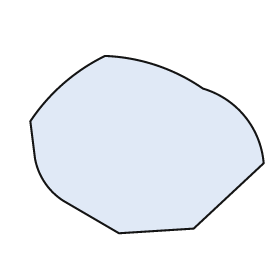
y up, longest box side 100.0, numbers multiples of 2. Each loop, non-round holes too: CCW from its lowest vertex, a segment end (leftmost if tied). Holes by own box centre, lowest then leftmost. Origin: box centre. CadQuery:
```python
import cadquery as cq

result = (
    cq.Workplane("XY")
    .moveTo(-12.0, -38.0)
    .lineTo(20.0, -36.0)
    .lineTo(50.0, -8.0)
    .threePointArc((42.0, 12.0), (24.0, 24.0))
    .threePointArc((4.0, 34.0), (-18.0, 38.0))
    .threePointArc((-36.0, 26.0), (-50.0, 10.0))
    .lineTo(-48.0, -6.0)
    .threePointArc((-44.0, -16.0), (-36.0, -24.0))
    .close()
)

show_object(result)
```